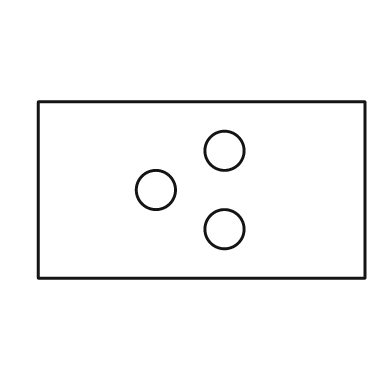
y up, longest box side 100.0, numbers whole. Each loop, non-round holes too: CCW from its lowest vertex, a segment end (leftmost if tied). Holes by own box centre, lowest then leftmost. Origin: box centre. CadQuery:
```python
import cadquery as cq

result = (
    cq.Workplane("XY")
    .moveTo(-50.0, -27.0)
    .lineTo(50.0, -27.0)
    .lineTo(50.0, 27.0)
    .lineTo(-50.0, 27.0)
    .close()
    .moveTo(7.0, -12.0)
    .circle(6.0)
    .moveTo(-14.0, 0.0)
    .circle(6.0)
    .moveTo(7.0, 12.0)
    .circle(6.0)
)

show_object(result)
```